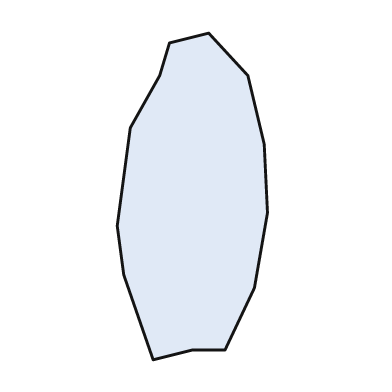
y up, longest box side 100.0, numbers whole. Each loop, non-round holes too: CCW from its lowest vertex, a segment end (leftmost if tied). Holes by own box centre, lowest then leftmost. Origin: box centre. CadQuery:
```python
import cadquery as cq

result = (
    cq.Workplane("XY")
    .moveTo(-12.0, -50.0)
    .lineTo(0.0, -47.0)
    .lineTo(10.0, -47.0)
    .lineTo(19.0, -28.0)
    .lineTo(23.0, -5.0)
    .lineTo(22.0, 16.0)
    .lineTo(17.0, 37.0)
    .lineTo(5.0, 50.0)
    .lineTo(-7.0, 47.0)
    .lineTo(-10.0, 37.0)
    .lineTo(-19.0, 21.0)
    .lineTo(-23.0, -9.0)
    .lineTo(-21.0, -24.0)
    .close()
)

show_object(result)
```